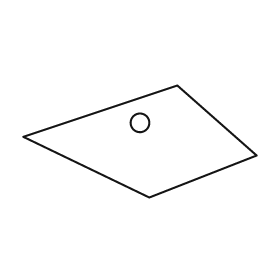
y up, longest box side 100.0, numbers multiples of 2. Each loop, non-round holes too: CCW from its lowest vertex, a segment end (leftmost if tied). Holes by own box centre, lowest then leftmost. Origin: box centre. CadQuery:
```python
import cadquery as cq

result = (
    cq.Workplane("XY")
    .moveTo(4.0, -24.0)
    .lineTo(50.0, -6.0)
    .lineTo(16.0, 24.0)
    .lineTo(-50.0, 2.0)
    .close()
    .moveTo(0.0, 8.0)
    .circle(4.0)
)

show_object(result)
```